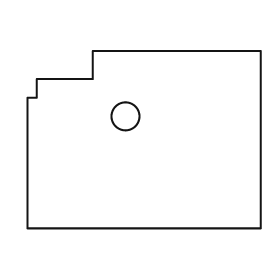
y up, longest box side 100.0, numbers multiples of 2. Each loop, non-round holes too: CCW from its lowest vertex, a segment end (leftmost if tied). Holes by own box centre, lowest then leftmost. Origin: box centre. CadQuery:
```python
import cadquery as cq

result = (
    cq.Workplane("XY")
    .moveTo(-50.0, -38.0)
    .lineTo(50.0, -38.0)
    .lineTo(50.0, 38.0)
    .lineTo(-22.0, 38.0)
    .lineTo(-22.0, 26.0)
    .lineTo(-46.0, 26.0)
    .lineTo(-46.0, 18.0)
    .lineTo(-50.0, 18.0)
    .close()
    .moveTo(-8.0, 10.0)
    .circle(6.0)
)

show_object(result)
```